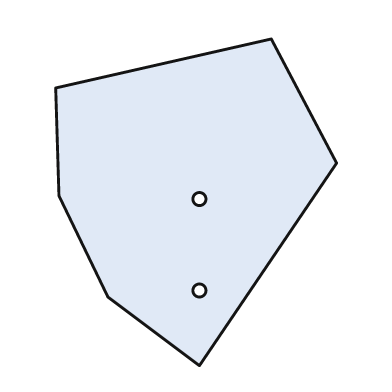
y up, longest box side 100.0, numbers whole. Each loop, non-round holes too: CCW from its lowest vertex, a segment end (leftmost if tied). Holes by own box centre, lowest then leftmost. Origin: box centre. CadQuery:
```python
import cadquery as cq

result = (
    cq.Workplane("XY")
    .moveTo(1.0, -50.0)
    .lineTo(43.0, 12.0)
    .lineTo(23.0, 50.0)
    .lineTo(-43.0, 35.0)
    .lineTo(-42.0, 2.0)
    .lineTo(-27.0, -29.0)
    .close()
    .moveTo(1.0, -27.0)
    .circle(2.0)
    .moveTo(1.0, 1.0)
    .circle(2.0)
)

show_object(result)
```